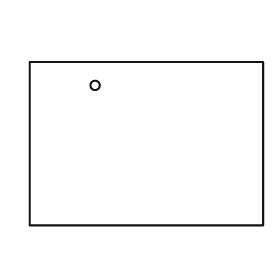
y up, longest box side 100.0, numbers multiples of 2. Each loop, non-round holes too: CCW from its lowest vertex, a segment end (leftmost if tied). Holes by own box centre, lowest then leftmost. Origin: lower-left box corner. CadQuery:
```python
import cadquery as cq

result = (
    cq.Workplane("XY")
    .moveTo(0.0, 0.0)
    .lineTo(100.0, 0.0)
    .lineTo(100.0, 70.0)
    .lineTo(0.0, 70.0)
    .close()
    .moveTo(28.0, 60.0)
    .circle(2.0)
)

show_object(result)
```